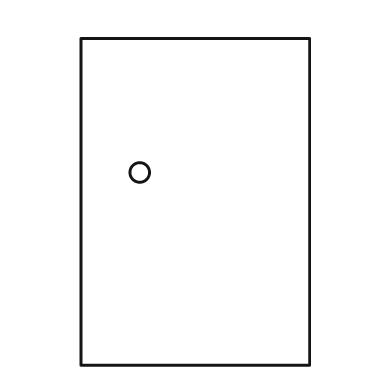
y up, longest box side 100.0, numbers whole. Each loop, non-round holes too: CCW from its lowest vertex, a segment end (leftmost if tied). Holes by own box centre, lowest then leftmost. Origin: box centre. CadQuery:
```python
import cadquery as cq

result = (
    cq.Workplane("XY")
    .moveTo(-35.0, -50.0)
    .lineTo(35.0, -50.0)
    .lineTo(35.0, 50.0)
    .lineTo(-35.0, 50.0)
    .close()
    .moveTo(-17.0, 9.0)
    .circle(3.0)
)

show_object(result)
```